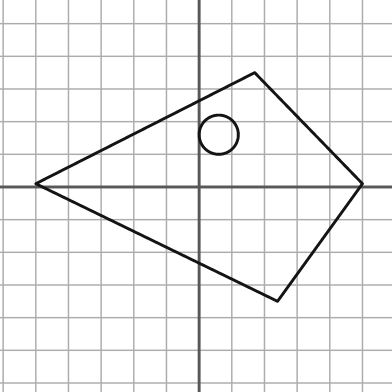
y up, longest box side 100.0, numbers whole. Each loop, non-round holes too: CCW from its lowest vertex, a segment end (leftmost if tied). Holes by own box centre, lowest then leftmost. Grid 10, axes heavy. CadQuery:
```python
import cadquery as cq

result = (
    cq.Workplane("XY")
    .moveTo(24.0, -35.0)
    .lineTo(50.0, 1.0)
    .lineTo(17.0, 35.0)
    .lineTo(-50.0, 1.0)
    .close()
    .moveTo(6.0, 16.0)
    .circle(6.0)
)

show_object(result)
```